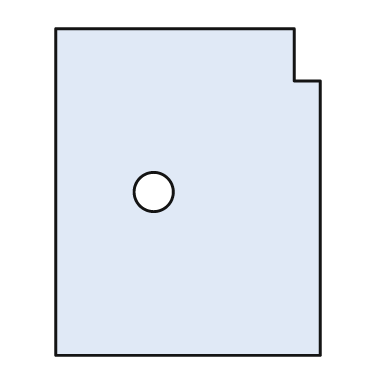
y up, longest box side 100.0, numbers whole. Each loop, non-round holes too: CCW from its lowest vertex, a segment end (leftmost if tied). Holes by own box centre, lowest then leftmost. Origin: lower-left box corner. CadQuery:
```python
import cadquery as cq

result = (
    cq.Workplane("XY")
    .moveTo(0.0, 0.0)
    .lineTo(81.0, 0.0)
    .lineTo(81.0, 84.0)
    .lineTo(73.0, 84.0)
    .lineTo(73.0, 100.0)
    .lineTo(0.0, 100.0)
    .close()
    .moveTo(30.0, 50.0)
    .circle(6.0)
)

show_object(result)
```